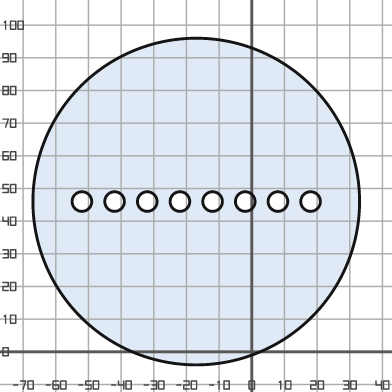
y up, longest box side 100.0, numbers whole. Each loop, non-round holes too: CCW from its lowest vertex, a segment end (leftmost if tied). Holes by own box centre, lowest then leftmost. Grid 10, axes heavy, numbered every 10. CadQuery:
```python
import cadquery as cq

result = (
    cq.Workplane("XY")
    .moveTo(-17.0, 46.0)
    .circle(50.0)
    .moveTo(-52.0, 46.0)
    .circle(3.0)
    .moveTo(-42.0, 46.0)
    .circle(3.0)
    .moveTo(-32.0, 46.0)
    .circle(3.0)
    .moveTo(-22.0, 46.0)
    .circle(3.0)
    .moveTo(-12.0, 46.0)
    .circle(3.0)
    .moveTo(-2.0, 46.0)
    .circle(3.0)
    .moveTo(8.0, 46.0)
    .circle(3.0)
    .moveTo(18.0, 46.0)
    .circle(3.0)
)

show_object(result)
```